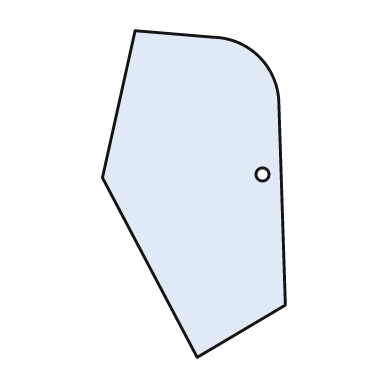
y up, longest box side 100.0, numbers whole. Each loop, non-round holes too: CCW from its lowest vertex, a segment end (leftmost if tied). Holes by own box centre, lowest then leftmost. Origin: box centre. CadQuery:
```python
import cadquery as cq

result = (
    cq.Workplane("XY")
    .moveTo(1.0, -50.0)
    .lineTo(28.0, -34.0)
    .lineTo(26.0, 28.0)
    .threePointArc((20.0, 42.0), (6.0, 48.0))
    .lineTo(-18.0, 50.0)
    .lineTo(-28.0, 5.0)
    .close()
    .moveTo(21.0, 6.0)
    .circle(2.0)
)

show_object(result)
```